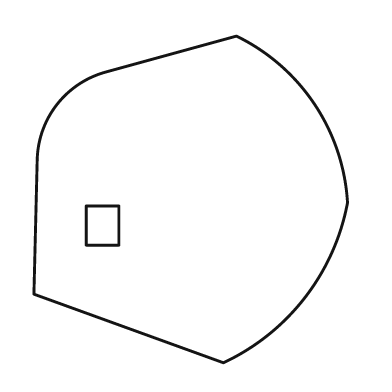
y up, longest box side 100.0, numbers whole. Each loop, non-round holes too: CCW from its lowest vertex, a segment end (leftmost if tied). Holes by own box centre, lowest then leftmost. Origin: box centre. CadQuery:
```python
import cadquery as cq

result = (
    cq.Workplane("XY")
    .moveTo(10.0, -50.0)
    .threePointArc((35.0, -30.0), (48.0, -1.0))
    .threePointArc((38.0, 29.0), (14.0, 50.0))
    .lineTo(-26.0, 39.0)
    .threePointArc((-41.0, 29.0), (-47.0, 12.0))
    .lineTo(-48.0, -29.0)
    .close()
    .moveTo(-32.0, -14.0)
    .lineTo(-22.0, -14.0)
    .lineTo(-22.0, -2.0)
    .lineTo(-32.0, -2.0)
    .close()
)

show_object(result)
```